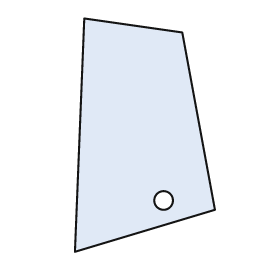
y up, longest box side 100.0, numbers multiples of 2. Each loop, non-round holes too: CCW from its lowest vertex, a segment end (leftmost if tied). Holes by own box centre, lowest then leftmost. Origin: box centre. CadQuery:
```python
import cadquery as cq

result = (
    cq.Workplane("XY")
    .moveTo(-30.0, -50.0)
    .lineTo(30.0, -32.0)
    .lineTo(16.0, 44.0)
    .lineTo(-26.0, 50.0)
    .close()
    .moveTo(8.0, -28.0)
    .circle(4.0)
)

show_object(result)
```